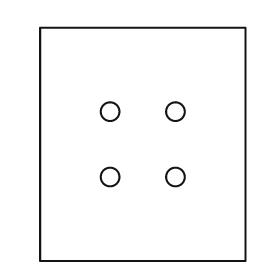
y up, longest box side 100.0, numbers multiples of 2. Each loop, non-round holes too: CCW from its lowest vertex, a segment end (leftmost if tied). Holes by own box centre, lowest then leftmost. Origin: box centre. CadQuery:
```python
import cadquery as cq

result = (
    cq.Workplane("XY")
    .moveTo(-44.0, -50.0)
    .lineTo(44.0, -50.0)
    .lineTo(44.0, 50.0)
    .lineTo(-44.0, 50.0)
    .close()
    .moveTo(-14.0, -14.0)
    .circle(4.0)
    .moveTo(14.0, -14.0)
    .circle(4.0)
    .moveTo(-14.0, 14.0)
    .circle(4.0)
    .moveTo(14.0, 14.0)
    .circle(4.0)
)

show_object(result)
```